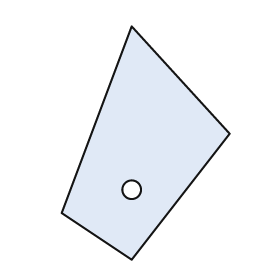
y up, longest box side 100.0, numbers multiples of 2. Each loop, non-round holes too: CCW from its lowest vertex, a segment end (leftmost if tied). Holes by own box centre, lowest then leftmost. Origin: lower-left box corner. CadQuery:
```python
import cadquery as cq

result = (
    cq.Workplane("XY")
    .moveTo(30.0, 0.0)
    .lineTo(72.0, 54.0)
    .lineTo(30.0, 100.0)
    .lineTo(0.0, 20.0)
    .close()
    .moveTo(30.0, 30.0)
    .circle(4.0)
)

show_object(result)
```